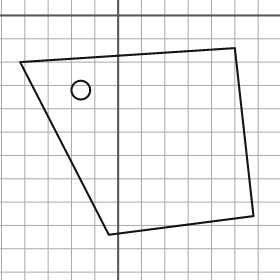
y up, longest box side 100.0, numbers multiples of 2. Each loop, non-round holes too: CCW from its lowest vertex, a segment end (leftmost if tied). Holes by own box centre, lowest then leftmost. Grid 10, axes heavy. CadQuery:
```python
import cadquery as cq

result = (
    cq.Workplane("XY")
    .moveTo(-4.0, -94.0)
    .lineTo(58.0, -86.0)
    .lineTo(50.0, -14.0)
    .lineTo(-42.0, -20.0)
    .close()
    .moveTo(-16.0, -32.0)
    .circle(4.0)
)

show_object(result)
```